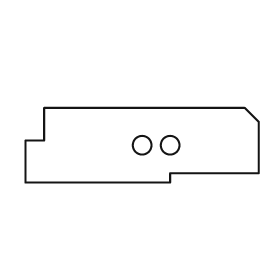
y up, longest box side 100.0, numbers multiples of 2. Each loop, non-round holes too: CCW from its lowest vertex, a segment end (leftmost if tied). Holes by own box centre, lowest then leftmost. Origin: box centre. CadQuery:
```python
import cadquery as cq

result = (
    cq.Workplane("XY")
    .moveTo(-50.0, -16.0)
    .lineTo(12.0, -16.0)
    .lineTo(12.0, -12.0)
    .lineTo(50.0, -12.0)
    .lineTo(50.0, 10.0)
    .lineTo(44.0, 16.0)
    .lineTo(-42.0, 16.0)
    .lineTo(-42.0, 2.0)
    .lineTo(-50.0, 2.0)
    .close()
    .moveTo(0.0, 0.0)
    .circle(4.0)
    .moveTo(12.0, 0.0)
    .circle(4.0)
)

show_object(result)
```